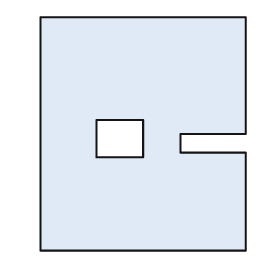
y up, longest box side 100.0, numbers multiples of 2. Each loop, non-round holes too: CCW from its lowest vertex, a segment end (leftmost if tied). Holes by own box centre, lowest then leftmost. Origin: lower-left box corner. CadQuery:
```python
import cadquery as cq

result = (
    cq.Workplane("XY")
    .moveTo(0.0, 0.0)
    .lineTo(88.0, 0.0)
    .lineTo(88.0, 42.0)
    .lineTo(60.0, 42.0)
    .lineTo(60.0, 50.0)
    .lineTo(88.0, 50.0)
    .lineTo(88.0, 100.0)
    .lineTo(0.0, 100.0)
    .close()
    .moveTo(24.0, 40.0)
    .lineTo(44.0, 40.0)
    .lineTo(44.0, 56.0)
    .lineTo(24.0, 56.0)
    .close()
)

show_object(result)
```